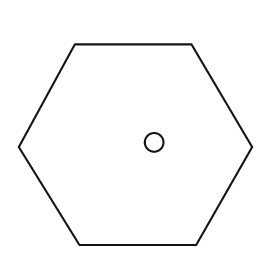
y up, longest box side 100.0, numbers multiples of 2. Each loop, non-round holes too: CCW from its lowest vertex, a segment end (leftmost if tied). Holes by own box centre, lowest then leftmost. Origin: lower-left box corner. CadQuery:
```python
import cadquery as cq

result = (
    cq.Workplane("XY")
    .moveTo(26.0, 0.0)
    .lineTo(76.0, 0.0)
    .lineTo(100.0, 42.0)
    .lineTo(74.0, 86.0)
    .lineTo(24.0, 86.0)
    .lineTo(0.0, 42.0)
    .close()
    .moveTo(58.0, 44.0)
    .circle(4.0)
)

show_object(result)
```